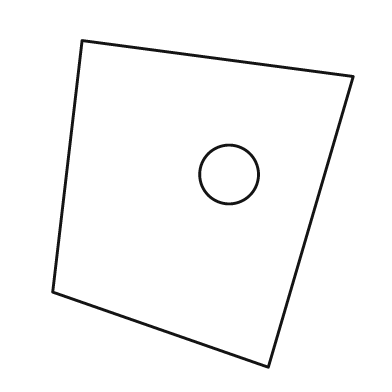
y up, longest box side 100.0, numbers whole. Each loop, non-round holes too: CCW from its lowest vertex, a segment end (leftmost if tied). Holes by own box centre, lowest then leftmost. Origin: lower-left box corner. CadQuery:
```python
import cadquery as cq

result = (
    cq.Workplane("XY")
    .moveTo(66.0, 0.0)
    .lineTo(92.0, 89.0)
    .lineTo(9.0, 100.0)
    .lineTo(0.0, 23.0)
    .close()
    .moveTo(54.0, 59.0)
    .circle(9.0)
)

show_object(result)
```